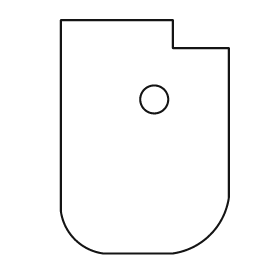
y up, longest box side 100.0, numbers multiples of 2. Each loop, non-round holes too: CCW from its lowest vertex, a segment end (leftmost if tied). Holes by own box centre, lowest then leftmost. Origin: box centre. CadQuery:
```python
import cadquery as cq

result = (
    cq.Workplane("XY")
    .moveTo(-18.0, -50.0)
    .lineTo(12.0, -50.0)
    .threePointArc((28.0, -42.0), (36.0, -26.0))
    .lineTo(36.0, 38.0)
    .lineTo(12.0, 38.0)
    .lineTo(12.0, 50.0)
    .lineTo(-36.0, 50.0)
    .lineTo(-36.0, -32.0)
    .threePointArc((-30.0, -44.0), (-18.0, -50.0))
    .close()
    .moveTo(4.0, 16.0)
    .circle(6.0)
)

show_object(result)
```